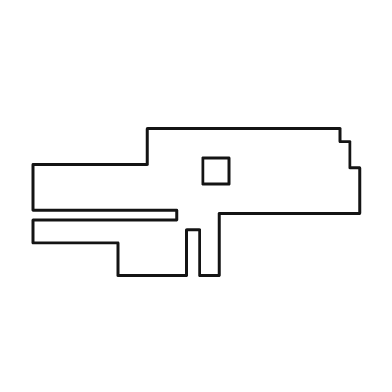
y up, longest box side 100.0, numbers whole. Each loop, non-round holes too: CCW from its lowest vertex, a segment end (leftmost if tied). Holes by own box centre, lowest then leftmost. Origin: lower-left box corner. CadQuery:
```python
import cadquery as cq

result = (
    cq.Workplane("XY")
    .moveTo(26.0, 0.0)
    .lineTo(47.0, 0.0)
    .lineTo(47.0, 14.0)
    .lineTo(51.0, 14.0)
    .lineTo(51.0, 0.0)
    .lineTo(57.0, 0.0)
    .lineTo(57.0, 19.0)
    .lineTo(100.0, 19.0)
    .lineTo(100.0, 33.0)
    .lineTo(97.0, 33.0)
    .lineTo(97.0, 41.0)
    .lineTo(94.0, 41.0)
    .lineTo(94.0, 45.0)
    .lineTo(35.0, 45.0)
    .lineTo(35.0, 34.0)
    .lineTo(0.0, 34.0)
    .lineTo(0.0, 20.0)
    .lineTo(44.0, 20.0)
    .lineTo(44.0, 17.0)
    .lineTo(0.0, 17.0)
    .lineTo(0.0, 10.0)
    .lineTo(26.0, 10.0)
    .close()
    .moveTo(52.0, 28.0)
    .lineTo(60.0, 28.0)
    .lineTo(60.0, 36.0)
    .lineTo(52.0, 36.0)
    .close()
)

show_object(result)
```